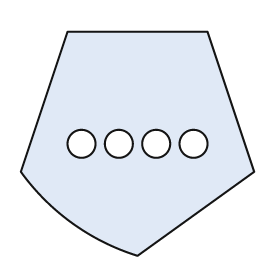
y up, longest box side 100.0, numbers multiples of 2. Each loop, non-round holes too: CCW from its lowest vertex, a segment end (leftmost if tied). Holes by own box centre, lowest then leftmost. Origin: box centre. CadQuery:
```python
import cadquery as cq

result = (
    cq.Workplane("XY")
    .moveTo(0.0, -48.0)
    .lineTo(50.0, -12.0)
    .lineTo(30.0, 48.0)
    .lineTo(-30.0, 48.0)
    .lineTo(-50.0, -12.0)
    .threePointArc((-28.0, -34.0), (0.0, -48.0))
    .close()
    .moveTo(-24.0, 0.0)
    .circle(6.0)
    .moveTo(-8.0, 0.0)
    .circle(6.0)
    .moveTo(8.0, 0.0)
    .circle(6.0)
    .moveTo(24.0, 0.0)
    .circle(6.0)
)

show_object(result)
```